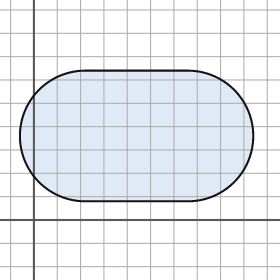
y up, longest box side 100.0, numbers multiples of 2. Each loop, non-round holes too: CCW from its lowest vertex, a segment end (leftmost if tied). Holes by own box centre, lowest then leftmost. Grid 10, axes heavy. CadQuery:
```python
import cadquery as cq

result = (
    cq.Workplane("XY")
    .moveTo(22.0, 8.0)
    .lineTo(66.0, 8.0)
    .threePointArc((94.0, 36.0), (66.0, 64.0))
    .lineTo(22.0, 64.0)
    .threePointArc((-6.0, 36.0), (22.0, 8.0))
    .close()
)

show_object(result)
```